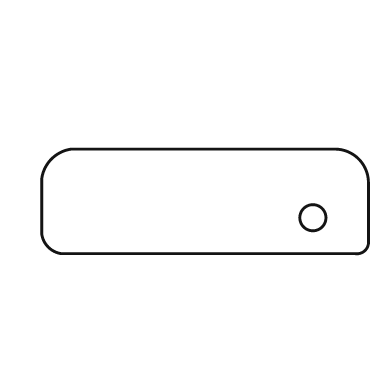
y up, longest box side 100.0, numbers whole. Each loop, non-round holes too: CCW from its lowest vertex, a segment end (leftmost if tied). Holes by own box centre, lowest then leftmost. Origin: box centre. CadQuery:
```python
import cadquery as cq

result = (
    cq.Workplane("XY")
    .moveTo(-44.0, -16.0)
    .lineTo(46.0, -16.0)
    .threePointArc((49.0, -15.0), (50.0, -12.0))
    .lineTo(50.0, 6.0)
    .threePointArc((47.0, 13.0), (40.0, 16.0))
    .lineTo(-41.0, 16.0)
    .threePointArc((-47.0, 13.0), (-50.0, 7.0))
    .lineTo(-50.0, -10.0)
    .threePointArc((-48.0, -14.0), (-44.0, -16.0))
    .close()
    .moveTo(33.0, -5.0)
    .circle(4.0)
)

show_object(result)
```